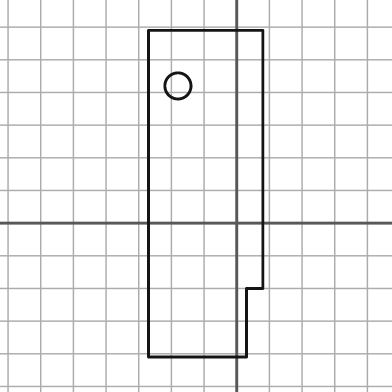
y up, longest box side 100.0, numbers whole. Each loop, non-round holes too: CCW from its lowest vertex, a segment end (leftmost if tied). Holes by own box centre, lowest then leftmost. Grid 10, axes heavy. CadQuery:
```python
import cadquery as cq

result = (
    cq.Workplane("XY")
    .moveTo(-27.0, -41.0)
    .lineTo(3.0, -41.0)
    .lineTo(3.0, -20.0)
    .lineTo(8.0, -20.0)
    .lineTo(8.0, 59.0)
    .lineTo(-27.0, 59.0)
    .close()
    .moveTo(-18.0, 42.0)
    .circle(4.0)
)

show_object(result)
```